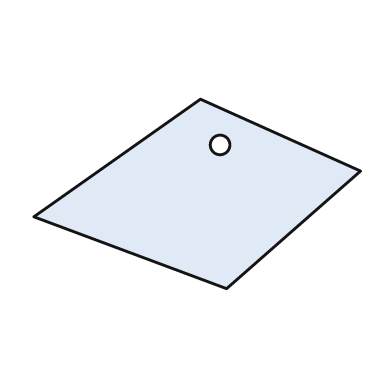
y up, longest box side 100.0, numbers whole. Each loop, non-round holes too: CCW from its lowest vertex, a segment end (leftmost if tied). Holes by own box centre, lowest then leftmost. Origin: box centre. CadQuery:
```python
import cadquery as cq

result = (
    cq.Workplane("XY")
    .moveTo(9.0, -29.0)
    .lineTo(50.0, 7.0)
    .lineTo(1.0, 29.0)
    .lineTo(-50.0, -7.0)
    .close()
    .moveTo(7.0, 15.0)
    .circle(3.0)
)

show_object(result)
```